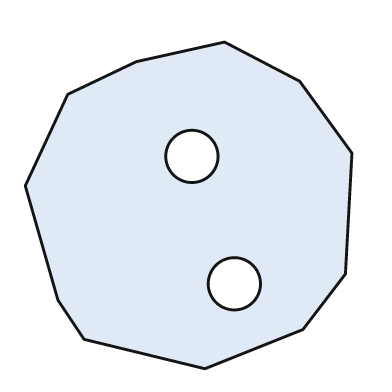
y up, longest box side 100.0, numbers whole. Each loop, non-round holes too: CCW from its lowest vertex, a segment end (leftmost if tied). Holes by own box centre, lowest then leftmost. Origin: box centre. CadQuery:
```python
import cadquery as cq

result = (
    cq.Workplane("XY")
    .moveTo(5.0, -50.0)
    .lineTo(35.0, -38.0)
    .lineTo(48.0, -21.0)
    .lineTo(50.0, 16.0)
    .lineTo(34.0, 38.0)
    .lineTo(11.0, 50.0)
    .lineTo(-16.0, 44.0)
    .lineTo(-37.0, 34.0)
    .lineTo(-50.0, 6.0)
    .lineTo(-40.0, -29.0)
    .lineTo(-32.0, -41.0)
    .close()
    .moveTo(14.0, -24.0)
    .circle(8.0)
    .moveTo(1.0, 15.0)
    .circle(8.0)
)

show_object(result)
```